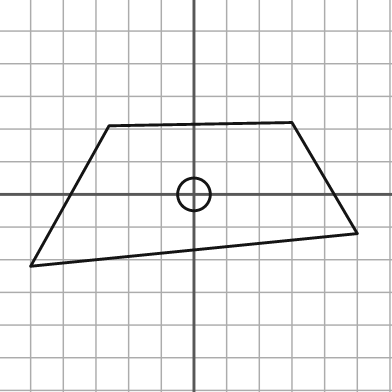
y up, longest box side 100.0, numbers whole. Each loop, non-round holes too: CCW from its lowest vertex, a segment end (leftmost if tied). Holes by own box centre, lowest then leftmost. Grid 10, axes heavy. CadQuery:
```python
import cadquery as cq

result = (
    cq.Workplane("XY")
    .moveTo(-50.0, -22.0)
    .lineTo(50.0, -12.0)
    .lineTo(30.0, 22.0)
    .lineTo(-26.0, 21.0)
    .close()
    .moveTo(0.0, 0.0)
    .circle(5.0)
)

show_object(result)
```